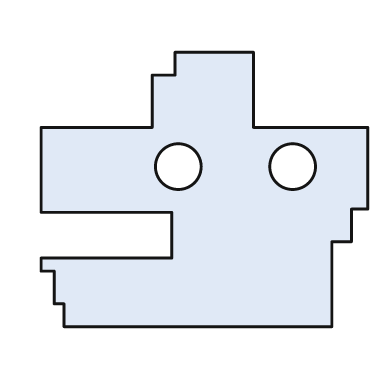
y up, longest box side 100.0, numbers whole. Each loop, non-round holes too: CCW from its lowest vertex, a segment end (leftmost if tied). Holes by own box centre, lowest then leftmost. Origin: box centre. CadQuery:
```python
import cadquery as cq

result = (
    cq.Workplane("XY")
    .moveTo(-43.0, -42.0)
    .lineTo(39.0, -42.0)
    .lineTo(39.0, -16.0)
    .lineTo(45.0, -16.0)
    .lineTo(45.0, -6.0)
    .lineTo(50.0, -6.0)
    .lineTo(50.0, 19.0)
    .lineTo(15.0, 19.0)
    .lineTo(15.0, 42.0)
    .lineTo(-9.0, 42.0)
    .lineTo(-9.0, 35.0)
    .lineTo(-16.0, 35.0)
    .lineTo(-16.0, 19.0)
    .lineTo(-50.0, 19.0)
    .lineTo(-50.0, -7.0)
    .lineTo(-10.0, -7.0)
    .lineTo(-10.0, -21.0)
    .lineTo(-50.0, -21.0)
    .lineTo(-50.0, -25.0)
    .lineTo(-46.0, -25.0)
    .lineTo(-46.0, -35.0)
    .lineTo(-43.0, -35.0)
    .close()
    .moveTo(-8.0, 7.0)
    .circle(7.0)
    .moveTo(27.0, 7.0)
    .circle(7.0)
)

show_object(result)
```